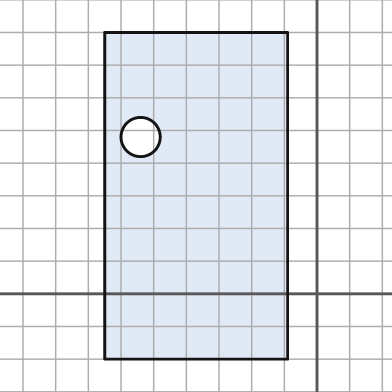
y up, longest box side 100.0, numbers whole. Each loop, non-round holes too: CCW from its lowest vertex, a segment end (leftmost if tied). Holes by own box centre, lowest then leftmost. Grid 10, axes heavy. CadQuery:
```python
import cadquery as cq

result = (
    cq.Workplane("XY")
    .moveTo(-65.0, -20.0)
    .lineTo(-9.0, -20.0)
    .lineTo(-9.0, 80.0)
    .lineTo(-65.0, 80.0)
    .close()
    .moveTo(-54.0, 48.0)
    .circle(6.0)
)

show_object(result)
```